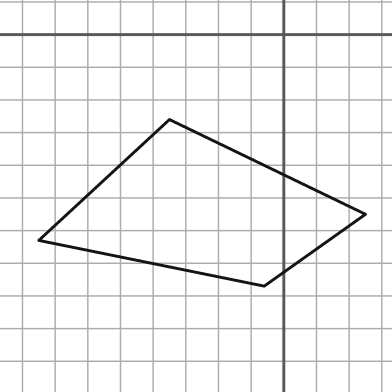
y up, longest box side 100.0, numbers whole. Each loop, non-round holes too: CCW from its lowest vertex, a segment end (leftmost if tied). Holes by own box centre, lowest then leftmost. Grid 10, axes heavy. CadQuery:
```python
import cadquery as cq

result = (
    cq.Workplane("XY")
    .moveTo(-6.0, -77.0)
    .lineTo(25.0, -55.0)
    .lineTo(-35.0, -26.0)
    .lineTo(-75.0, -63.0)
    .close()
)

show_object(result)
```